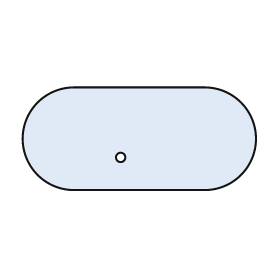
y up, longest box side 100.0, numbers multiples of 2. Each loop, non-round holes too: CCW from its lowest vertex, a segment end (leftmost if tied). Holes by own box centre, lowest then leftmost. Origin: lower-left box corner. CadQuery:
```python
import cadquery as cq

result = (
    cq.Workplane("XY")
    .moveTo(22.0, 0.0)
    .lineTo(78.0, 0.0)
    .threePointArc((100.0, 22.0), (78.0, 44.0))
    .lineTo(22.0, 44.0)
    .threePointArc((0.0, 22.0), (22.0, 0.0))
    .close()
    .moveTo(42.0, 14.0)
    .circle(2.0)
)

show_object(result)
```